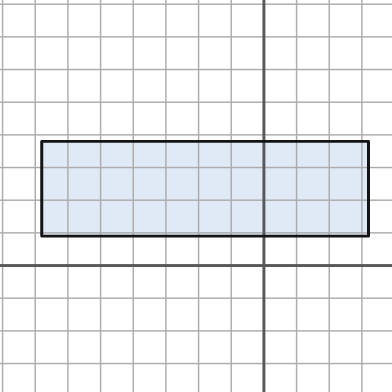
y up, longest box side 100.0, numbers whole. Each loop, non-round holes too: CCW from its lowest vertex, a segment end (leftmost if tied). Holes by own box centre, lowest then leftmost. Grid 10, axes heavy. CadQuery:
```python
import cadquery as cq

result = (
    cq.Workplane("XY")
    .moveTo(-68.0, 9.0)
    .lineTo(32.0, 9.0)
    .lineTo(32.0, 38.0)
    .lineTo(-68.0, 38.0)
    .close()
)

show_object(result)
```